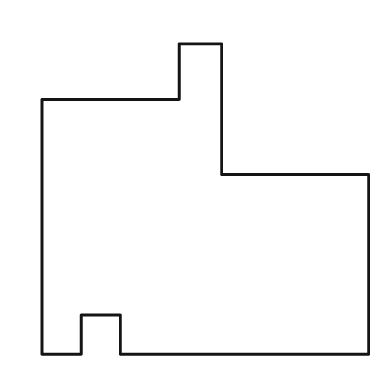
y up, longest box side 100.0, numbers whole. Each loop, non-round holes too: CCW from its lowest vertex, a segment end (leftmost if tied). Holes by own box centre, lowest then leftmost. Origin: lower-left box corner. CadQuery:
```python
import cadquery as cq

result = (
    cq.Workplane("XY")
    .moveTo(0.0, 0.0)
    .lineTo(12.0, 0.0)
    .lineTo(12.0, 12.0)
    .lineTo(24.0, 12.0)
    .lineTo(24.0, 0.0)
    .lineTo(100.0, 0.0)
    .lineTo(100.0, 55.0)
    .lineTo(55.0, 55.0)
    .lineTo(55.0, 95.0)
    .lineTo(42.0, 95.0)
    .lineTo(42.0, 78.0)
    .lineTo(0.0, 78.0)
    .close()
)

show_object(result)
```